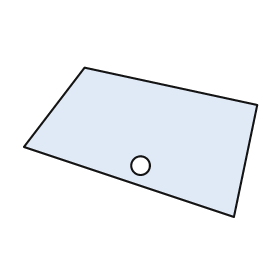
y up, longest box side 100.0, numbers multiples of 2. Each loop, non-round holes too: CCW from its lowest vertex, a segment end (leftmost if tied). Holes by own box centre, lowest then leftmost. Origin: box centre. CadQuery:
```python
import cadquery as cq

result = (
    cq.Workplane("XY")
    .moveTo(40.0, -32.0)
    .lineTo(50.0, 16.0)
    .lineTo(-24.0, 32.0)
    .lineTo(-50.0, -2.0)
    .close()
    .moveTo(0.0, -10.0)
    .circle(4.0)
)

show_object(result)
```